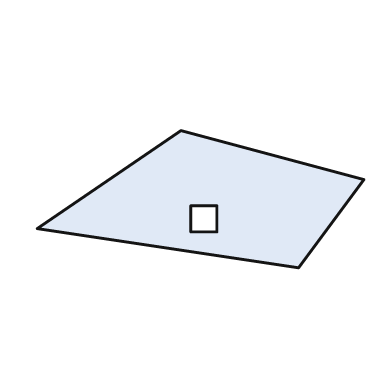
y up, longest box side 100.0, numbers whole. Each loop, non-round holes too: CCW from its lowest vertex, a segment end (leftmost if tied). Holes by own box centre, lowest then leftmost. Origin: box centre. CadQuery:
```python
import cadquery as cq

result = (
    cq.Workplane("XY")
    .moveTo(30.0, -21.0)
    .lineTo(50.0, 6.0)
    .lineTo(-6.0, 21.0)
    .lineTo(-50.0, -9.0)
    .close()
    .moveTo(-3.0, -10.0)
    .lineTo(5.0, -10.0)
    .lineTo(5.0, -2.0)
    .lineTo(-3.0, -2.0)
    .close()
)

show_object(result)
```